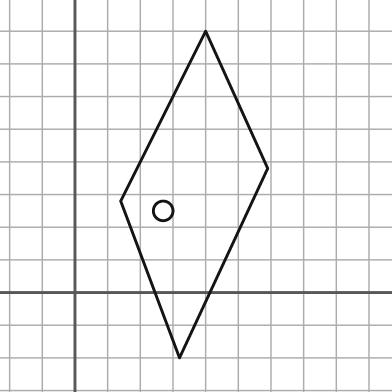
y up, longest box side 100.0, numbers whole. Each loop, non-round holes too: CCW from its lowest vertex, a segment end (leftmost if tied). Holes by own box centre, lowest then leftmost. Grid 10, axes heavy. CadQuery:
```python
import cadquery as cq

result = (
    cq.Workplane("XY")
    .moveTo(32.0, -20.0)
    .lineTo(59.0, 38.0)
    .lineTo(40.0, 80.0)
    .lineTo(14.0, 28.0)
    .close()
    .moveTo(27.0, 25.0)
    .circle(3.0)
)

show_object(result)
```